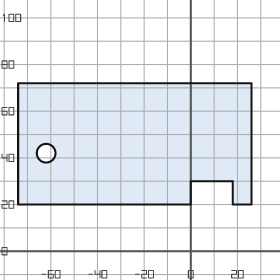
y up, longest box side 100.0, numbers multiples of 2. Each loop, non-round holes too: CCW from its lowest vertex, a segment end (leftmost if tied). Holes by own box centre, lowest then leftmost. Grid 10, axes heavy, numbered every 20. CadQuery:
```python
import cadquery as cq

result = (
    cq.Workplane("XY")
    .moveTo(-74.0, 20.0)
    .lineTo(0.0, 20.0)
    .lineTo(0.0, 30.0)
    .lineTo(18.0, 30.0)
    .lineTo(18.0, 20.0)
    .lineTo(26.0, 20.0)
    .lineTo(26.0, 72.0)
    .lineTo(-74.0, 72.0)
    .close()
    .moveTo(-62.0, 42.0)
    .circle(4.0)
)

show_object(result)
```